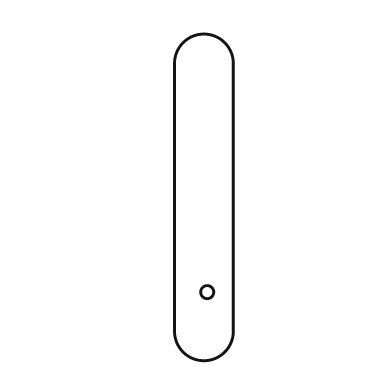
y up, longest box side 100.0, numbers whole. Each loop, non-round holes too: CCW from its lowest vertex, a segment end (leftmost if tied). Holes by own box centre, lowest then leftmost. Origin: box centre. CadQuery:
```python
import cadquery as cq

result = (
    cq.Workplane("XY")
    .moveTo(-9.0, -41.0)
    .threePointArc((0.0, -50.0), (9.0, -41.0))
    .lineTo(9.0, 41.0)
    .threePointArc((0.0, 50.0), (-9.0, 41.0))
    .close()
    .moveTo(1.0, -29.0)
    .circle(2.0)
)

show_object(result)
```